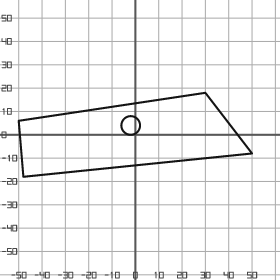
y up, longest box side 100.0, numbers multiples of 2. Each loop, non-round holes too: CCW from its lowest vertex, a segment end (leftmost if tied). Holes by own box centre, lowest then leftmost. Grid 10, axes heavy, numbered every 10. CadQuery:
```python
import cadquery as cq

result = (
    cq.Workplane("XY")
    .moveTo(-48.0, -18.0)
    .lineTo(50.0, -8.0)
    .lineTo(30.0, 18.0)
    .lineTo(-50.0, 6.0)
    .close()
    .moveTo(-2.0, 4.0)
    .circle(4.0)
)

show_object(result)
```